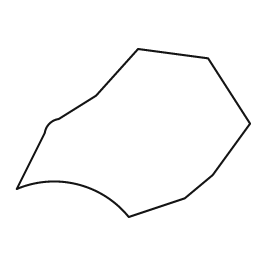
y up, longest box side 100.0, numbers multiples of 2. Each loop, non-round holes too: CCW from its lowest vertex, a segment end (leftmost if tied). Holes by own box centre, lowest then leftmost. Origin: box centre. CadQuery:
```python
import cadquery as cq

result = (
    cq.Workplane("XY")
    .moveTo(-2.0, -36.0)
    .lineTo(22.0, -28.0)
    .lineTo(34.0, -18.0)
    .lineTo(50.0, 4.0)
    .lineTo(32.0, 32.0)
    .lineTo(2.0, 36.0)
    .lineTo(-16.0, 16.0)
    .lineTo(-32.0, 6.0)
    .threePointArc((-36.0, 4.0), (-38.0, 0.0))
    .lineTo(-50.0, -24.0)
    .threePointArc((-24.0, -22.0), (-2.0, -36.0))
    .close()
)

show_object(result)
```